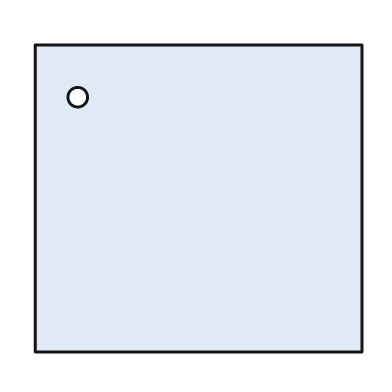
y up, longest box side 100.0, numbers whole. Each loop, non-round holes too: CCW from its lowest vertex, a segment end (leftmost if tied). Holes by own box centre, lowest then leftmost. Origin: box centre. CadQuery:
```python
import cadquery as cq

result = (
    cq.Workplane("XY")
    .moveTo(-50.0, -47.0)
    .lineTo(50.0, -47.0)
    .lineTo(50.0, 47.0)
    .lineTo(-50.0, 47.0)
    .close()
    .moveTo(-37.0, 31.0)
    .circle(3.0)
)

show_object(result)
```